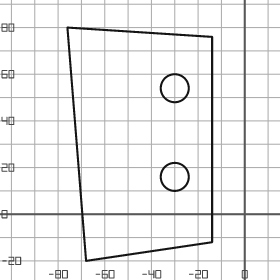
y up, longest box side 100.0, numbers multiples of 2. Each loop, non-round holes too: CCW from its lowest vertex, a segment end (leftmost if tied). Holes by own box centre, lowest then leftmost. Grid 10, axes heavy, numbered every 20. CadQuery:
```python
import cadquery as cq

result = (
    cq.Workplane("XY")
    .moveTo(-68.0, -20.0)
    .lineTo(-14.0, -12.0)
    .lineTo(-14.0, 76.0)
    .lineTo(-76.0, 80.0)
    .close()
    .moveTo(-30.0, 16.0)
    .circle(6.0)
    .moveTo(-30.0, 54.0)
    .circle(6.0)
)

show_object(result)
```